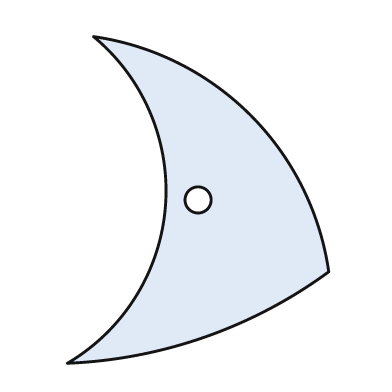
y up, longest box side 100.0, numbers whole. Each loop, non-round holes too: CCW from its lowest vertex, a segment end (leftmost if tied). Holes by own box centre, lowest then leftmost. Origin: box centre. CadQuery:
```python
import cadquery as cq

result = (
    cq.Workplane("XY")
    .moveTo(-40.0, -50.0)
    .threePointArc((2.0, -42.0), (40.0, -22.0))
    .threePointArc((16.0, 26.0), (-32.0, 50.0))
    .threePointArc((-10.0, -2.0), (-40.0, -50.0))
    .close()
    .moveTo(0.0, 0.0)
    .circle(4.0)
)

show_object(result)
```